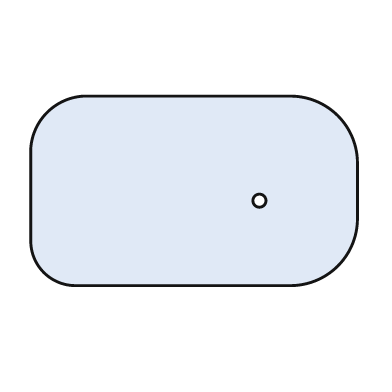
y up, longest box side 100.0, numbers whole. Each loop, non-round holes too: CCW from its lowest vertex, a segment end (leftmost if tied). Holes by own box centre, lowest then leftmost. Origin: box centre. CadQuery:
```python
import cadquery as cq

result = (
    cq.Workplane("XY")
    .moveTo(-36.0, -29.0)
    .lineTo(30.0, -29.0)
    .threePointArc((44.0, -23.0), (50.0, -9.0))
    .lineTo(50.0, 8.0)
    .threePointArc((44.0, 23.0), (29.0, 29.0))
    .lineTo(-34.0, 29.0)
    .threePointArc((-45.0, 24.0), (-50.0, 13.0))
    .lineTo(-50.0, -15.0)
    .threePointArc((-46.0, -25.0), (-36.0, -29.0))
    .close()
    .moveTo(20.0, -3.0)
    .circle(2.0)
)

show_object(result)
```